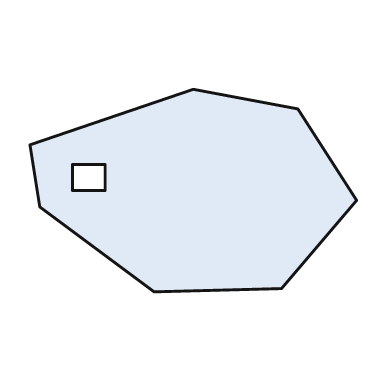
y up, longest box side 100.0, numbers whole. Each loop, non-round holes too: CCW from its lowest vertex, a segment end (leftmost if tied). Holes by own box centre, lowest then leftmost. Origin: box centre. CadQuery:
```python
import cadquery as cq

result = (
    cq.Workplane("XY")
    .moveTo(-12.0, -31.0)
    .lineTo(27.0, -30.0)
    .lineTo(50.0, -3.0)
    .lineTo(32.0, 25.0)
    .lineTo(0.0, 31.0)
    .lineTo(-50.0, 14.0)
    .lineTo(-47.0, -5.0)
    .close()
    .moveTo(-37.0, 0.0)
    .lineTo(-27.0, 0.0)
    .lineTo(-27.0, 8.0)
    .lineTo(-37.0, 8.0)
    .close()
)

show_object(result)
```